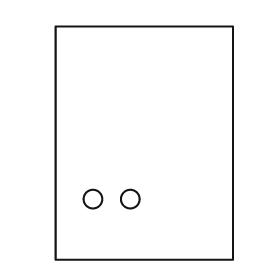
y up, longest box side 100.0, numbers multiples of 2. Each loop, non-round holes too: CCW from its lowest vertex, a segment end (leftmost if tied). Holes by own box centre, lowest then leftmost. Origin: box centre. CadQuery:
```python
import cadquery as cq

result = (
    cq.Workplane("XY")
    .moveTo(-38.0, -50.0)
    .lineTo(38.0, -50.0)
    .lineTo(38.0, 50.0)
    .lineTo(-38.0, 50.0)
    .close()
    .moveTo(-22.0, -24.0)
    .circle(4.0)
    .moveTo(-6.0, -24.0)
    .circle(4.0)
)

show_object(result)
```